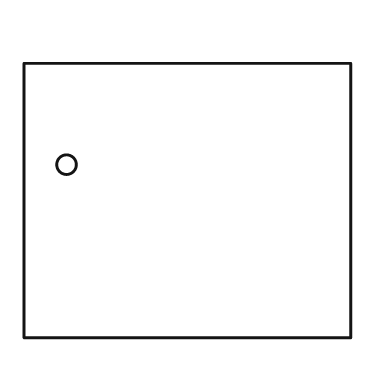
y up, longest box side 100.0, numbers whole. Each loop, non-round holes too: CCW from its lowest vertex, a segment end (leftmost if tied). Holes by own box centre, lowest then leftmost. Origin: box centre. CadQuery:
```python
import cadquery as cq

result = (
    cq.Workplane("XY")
    .moveTo(-50.0, -42.0)
    .lineTo(50.0, -42.0)
    .lineTo(50.0, 42.0)
    .lineTo(-50.0, 42.0)
    .close()
    .moveTo(-37.0, 11.0)
    .circle(3.0)
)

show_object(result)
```